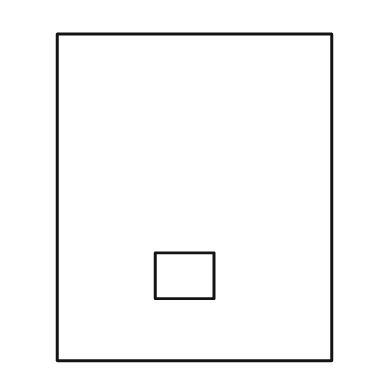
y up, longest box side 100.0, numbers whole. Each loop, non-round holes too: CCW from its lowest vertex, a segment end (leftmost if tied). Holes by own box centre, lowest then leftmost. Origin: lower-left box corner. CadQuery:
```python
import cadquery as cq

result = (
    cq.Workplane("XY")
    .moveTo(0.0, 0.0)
    .lineTo(84.0, 0.0)
    .lineTo(84.0, 100.0)
    .lineTo(0.0, 100.0)
    .close()
    .moveTo(30.0, 19.0)
    .lineTo(48.0, 19.0)
    .lineTo(48.0, 33.0)
    .lineTo(30.0, 33.0)
    .close()
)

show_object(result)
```